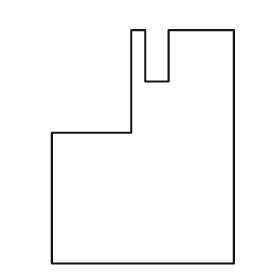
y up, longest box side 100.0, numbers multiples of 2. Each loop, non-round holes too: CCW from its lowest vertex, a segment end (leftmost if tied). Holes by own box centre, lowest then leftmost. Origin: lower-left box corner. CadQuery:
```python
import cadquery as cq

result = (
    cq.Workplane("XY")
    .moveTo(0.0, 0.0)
    .lineTo(78.0, 0.0)
    .lineTo(78.0, 100.0)
    .lineTo(50.0, 100.0)
    .lineTo(50.0, 78.0)
    .lineTo(40.0, 78.0)
    .lineTo(40.0, 100.0)
    .lineTo(34.0, 100.0)
    .lineTo(34.0, 56.0)
    .lineTo(0.0, 56.0)
    .close()
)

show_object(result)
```